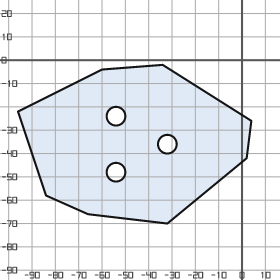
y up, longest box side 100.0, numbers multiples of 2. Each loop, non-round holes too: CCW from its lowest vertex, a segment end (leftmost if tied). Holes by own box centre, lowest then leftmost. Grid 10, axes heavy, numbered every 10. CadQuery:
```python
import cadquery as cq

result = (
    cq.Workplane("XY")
    .moveTo(-32.0, -70.0)
    .lineTo(2.0, -42.0)
    .lineTo(4.0, -26.0)
    .lineTo(-34.0, -2.0)
    .lineTo(-60.0, -4.0)
    .lineTo(-96.0, -22.0)
    .lineTo(-84.0, -58.0)
    .lineTo(-66.0, -66.0)
    .close()
    .moveTo(-54.0, -48.0)
    .circle(4.0)
    .moveTo(-32.0, -36.0)
    .circle(4.0)
    .moveTo(-54.0, -24.0)
    .circle(4.0)
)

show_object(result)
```